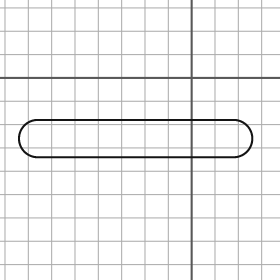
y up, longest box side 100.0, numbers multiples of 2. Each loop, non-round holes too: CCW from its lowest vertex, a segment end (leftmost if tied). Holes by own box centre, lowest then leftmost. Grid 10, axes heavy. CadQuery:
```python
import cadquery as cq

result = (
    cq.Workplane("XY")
    .moveTo(-66.0, -34.0)
    .lineTo(18.0, -34.0)
    .threePointArc((26.0, -26.0), (18.0, -18.0))
    .lineTo(-66.0, -18.0)
    .threePointArc((-74.0, -26.0), (-66.0, -34.0))
    .close()
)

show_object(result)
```